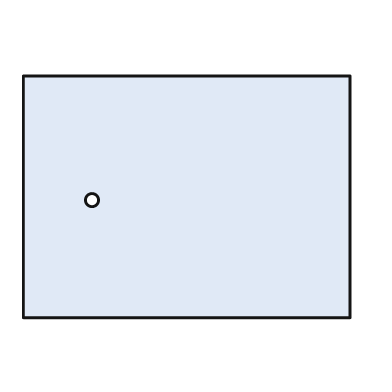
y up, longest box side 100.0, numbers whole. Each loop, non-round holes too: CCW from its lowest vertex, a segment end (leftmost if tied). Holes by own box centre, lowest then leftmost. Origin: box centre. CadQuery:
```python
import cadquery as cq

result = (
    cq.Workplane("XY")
    .moveTo(-50.0, -37.0)
    .lineTo(50.0, -37.0)
    .lineTo(50.0, 37.0)
    .lineTo(-50.0, 37.0)
    .close()
    .moveTo(-29.0, -1.0)
    .circle(2.0)
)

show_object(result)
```